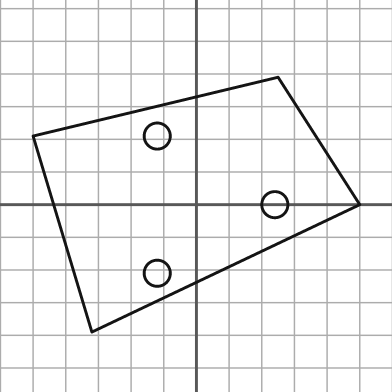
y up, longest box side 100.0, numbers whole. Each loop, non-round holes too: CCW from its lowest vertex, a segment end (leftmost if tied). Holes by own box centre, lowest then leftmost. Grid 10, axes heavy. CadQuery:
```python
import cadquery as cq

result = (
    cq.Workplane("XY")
    .moveTo(-32.0, -39.0)
    .lineTo(50.0, 0.0)
    .lineTo(25.0, 39.0)
    .lineTo(-50.0, 21.0)
    .close()
    .moveTo(-12.0, -21.0)
    .circle(4.0)
    .moveTo(24.0, 0.0)
    .circle(4.0)
    .moveTo(-12.0, 21.0)
    .circle(4.0)
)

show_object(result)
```